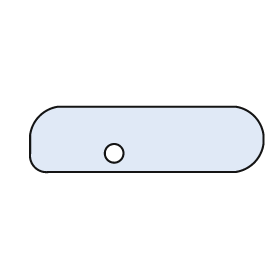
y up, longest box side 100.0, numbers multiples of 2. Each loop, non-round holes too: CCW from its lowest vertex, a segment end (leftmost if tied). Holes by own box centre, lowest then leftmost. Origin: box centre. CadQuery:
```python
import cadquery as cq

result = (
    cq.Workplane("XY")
    .moveTo(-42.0, -14.0)
    .lineTo(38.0, -14.0)
    .threePointArc((46.0, -10.0), (50.0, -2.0))
    .lineTo(50.0, 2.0)
    .threePointArc((46.0, 10.0), (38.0, 14.0))
    .lineTo(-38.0, 14.0)
    .threePointArc((-46.0, 10.0), (-50.0, 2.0))
    .lineTo(-50.0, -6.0)
    .threePointArc((-48.0, -12.0), (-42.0, -14.0))
    .close()
    .moveTo(-14.0, -6.0)
    .circle(4.0)
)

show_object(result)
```